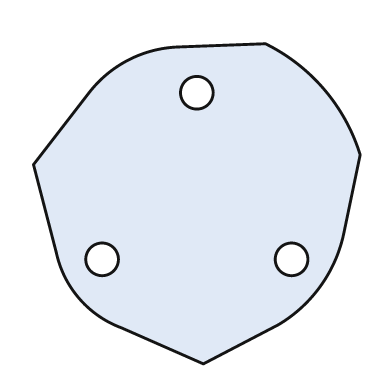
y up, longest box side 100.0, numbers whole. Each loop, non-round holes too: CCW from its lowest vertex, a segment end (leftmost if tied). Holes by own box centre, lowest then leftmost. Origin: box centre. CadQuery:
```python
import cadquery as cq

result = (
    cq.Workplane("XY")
    .moveTo(2.0, -49.0)
    .lineTo(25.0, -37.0)
    .threePointArc((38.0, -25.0), (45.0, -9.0))
    .lineTo(50.0, 15.0)
    .threePointArc((39.0, 35.0), (21.0, 49.0))
    .lineTo(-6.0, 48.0)
    .threePointArc((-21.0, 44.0), (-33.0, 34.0))
    .lineTo(-50.0, 12.0)
    .lineTo(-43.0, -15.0)
    .threePointArc((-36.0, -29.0), (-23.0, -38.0))
    .close()
    .moveTo(-29.0, -17.0)
    .circle(5.0)
    .moveTo(29.0, -17.0)
    .circle(5.0)
    .moveTo(0.0, 34.0)
    .circle(5.0)
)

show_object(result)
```